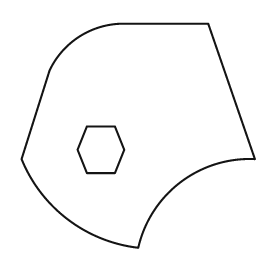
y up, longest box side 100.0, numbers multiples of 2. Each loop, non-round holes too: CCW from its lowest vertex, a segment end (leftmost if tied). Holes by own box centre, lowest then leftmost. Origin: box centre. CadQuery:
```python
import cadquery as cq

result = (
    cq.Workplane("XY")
    .moveTo(0.0, -48.0)
    .threePointArc((18.0, -20.0), (50.0, -10.0))
    .lineTo(30.0, 48.0)
    .lineTo(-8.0, 48.0)
    .threePointArc((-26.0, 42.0), (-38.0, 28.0))
    .lineTo(-50.0, -10.0)
    .threePointArc((-30.0, -36.0), (0.0, -48.0))
    .close()
    .moveTo(-22.0, -16.0)
    .lineTo(-10.0, -16.0)
    .lineTo(-6.0, -6.0)
    .lineTo(-10.0, 4.0)
    .lineTo(-22.0, 4.0)
    .lineTo(-26.0, -6.0)
    .close()
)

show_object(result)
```